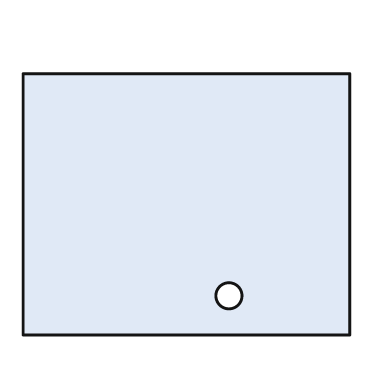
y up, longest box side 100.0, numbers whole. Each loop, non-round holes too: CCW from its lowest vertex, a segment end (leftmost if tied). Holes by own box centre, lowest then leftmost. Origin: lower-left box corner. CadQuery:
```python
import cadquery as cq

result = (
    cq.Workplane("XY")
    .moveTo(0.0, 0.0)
    .lineTo(100.0, 0.0)
    .lineTo(100.0, 80.0)
    .lineTo(0.0, 80.0)
    .close()
    .moveTo(63.0, 12.0)
    .circle(4.0)
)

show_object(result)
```